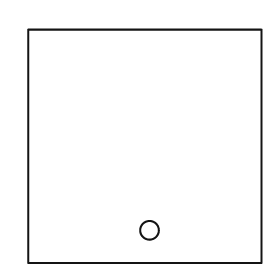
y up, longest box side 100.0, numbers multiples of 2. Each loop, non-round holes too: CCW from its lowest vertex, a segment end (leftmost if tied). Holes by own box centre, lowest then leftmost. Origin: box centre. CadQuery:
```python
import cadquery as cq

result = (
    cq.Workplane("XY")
    .moveTo(-50.0, -50.0)
    .lineTo(50.0, -50.0)
    .lineTo(50.0, 50.0)
    .lineTo(-50.0, 50.0)
    .close()
    .moveTo(2.0, -36.0)
    .circle(4.0)
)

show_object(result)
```